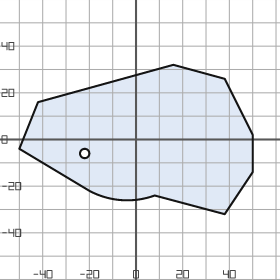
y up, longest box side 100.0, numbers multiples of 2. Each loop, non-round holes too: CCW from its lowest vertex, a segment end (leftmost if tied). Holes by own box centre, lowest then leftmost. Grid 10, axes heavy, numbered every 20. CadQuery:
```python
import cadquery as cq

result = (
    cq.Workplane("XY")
    .moveTo(38.0, -32.0)
    .lineTo(50.0, -14.0)
    .lineTo(50.0, 2.0)
    .lineTo(38.0, 26.0)
    .lineTo(16.0, 32.0)
    .lineTo(-42.0, 16.0)
    .lineTo(-50.0, -4.0)
    .lineTo(-20.0, -22.0)
    .threePointArc((-6.0, -26.0), (8.0, -24.0))
    .close()
    .moveTo(-22.0, -6.0)
    .circle(2.0)
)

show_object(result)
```